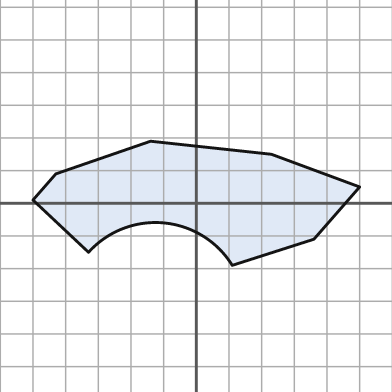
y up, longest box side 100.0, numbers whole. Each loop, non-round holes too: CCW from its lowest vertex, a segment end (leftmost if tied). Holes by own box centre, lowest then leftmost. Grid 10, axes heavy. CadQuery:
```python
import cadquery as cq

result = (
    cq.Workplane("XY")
    .moveTo(11.0, -19.0)
    .lineTo(36.0, -11.0)
    .lineTo(50.0, 5.0)
    .lineTo(23.0, 15.0)
    .lineTo(-14.0, 19.0)
    .lineTo(-43.0, 9.0)
    .lineTo(-50.0, 1.0)
    .lineTo(-33.0, -15.0)
    .threePointArc((-10.0, -6.0), (11.0, -19.0))
    .close()
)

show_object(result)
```